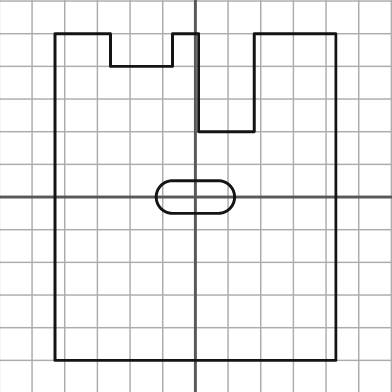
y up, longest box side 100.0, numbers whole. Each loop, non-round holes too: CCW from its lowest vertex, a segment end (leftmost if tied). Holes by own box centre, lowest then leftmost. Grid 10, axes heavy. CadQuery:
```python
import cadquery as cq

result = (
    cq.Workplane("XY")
    .moveTo(-43.0, -50.0)
    .lineTo(43.0, -50.0)
    .lineTo(43.0, 50.0)
    .lineTo(18.0, 50.0)
    .lineTo(18.0, 20.0)
    .lineTo(1.0, 20.0)
    .lineTo(1.0, 50.0)
    .lineTo(-7.0, 50.0)
    .lineTo(-7.0, 40.0)
    .lineTo(-26.0, 40.0)
    .lineTo(-26.0, 50.0)
    .lineTo(-43.0, 50.0)
    .close()
    .moveTo(-7.0, -5.0)
    .lineTo(7.0, -5.0)
    .threePointArc((12.0, 0.0), (7.0, 5.0))
    .lineTo(-7.0, 5.0)
    .threePointArc((-12.0, 0.0), (-7.0, -5.0))
    .close()
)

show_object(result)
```